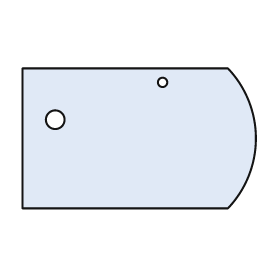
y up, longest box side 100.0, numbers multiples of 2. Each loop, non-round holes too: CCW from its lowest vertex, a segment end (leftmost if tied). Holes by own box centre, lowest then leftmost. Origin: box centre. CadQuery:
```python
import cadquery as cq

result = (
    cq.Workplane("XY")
    .moveTo(-50.0, -30.0)
    .lineTo(38.0, -30.0)
    .threePointArc((50.0, 0.0), (38.0, 30.0))
    .lineTo(-50.0, 30.0)
    .close()
    .moveTo(-36.0, 8.0)
    .circle(4.0)
    .moveTo(10.0, 24.0)
    .circle(2.0)
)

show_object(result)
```